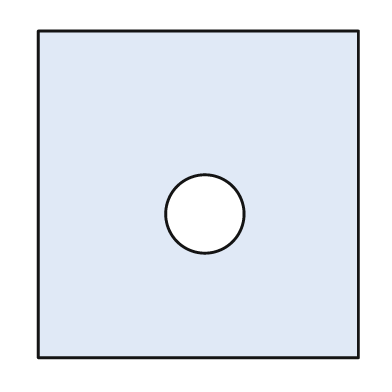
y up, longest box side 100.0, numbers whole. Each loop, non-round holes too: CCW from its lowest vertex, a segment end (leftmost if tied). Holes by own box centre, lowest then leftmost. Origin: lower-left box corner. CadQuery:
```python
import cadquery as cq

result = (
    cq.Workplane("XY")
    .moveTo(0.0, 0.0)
    .lineTo(98.0, 0.0)
    .lineTo(98.0, 100.0)
    .lineTo(0.0, 100.0)
    .close()
    .moveTo(51.0, 44.0)
    .circle(12.0)
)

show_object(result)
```